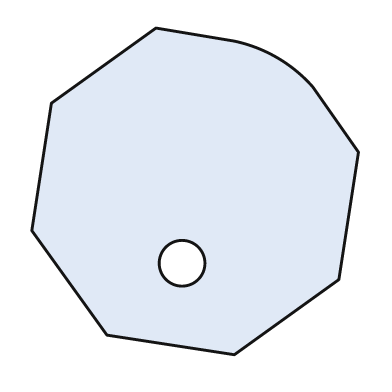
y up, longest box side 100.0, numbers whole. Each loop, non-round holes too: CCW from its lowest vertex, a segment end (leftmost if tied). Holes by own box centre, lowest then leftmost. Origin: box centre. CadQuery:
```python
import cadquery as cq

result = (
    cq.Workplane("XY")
    .moveTo(12.0, -50.0)
    .lineTo(44.0, -27.0)
    .lineTo(50.0, 12.0)
    .lineTo(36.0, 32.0)
    .threePointArc((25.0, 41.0), (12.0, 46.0))
    .lineTo(-12.0, 50.0)
    .lineTo(-44.0, 27.0)
    .lineTo(-50.0, -12.0)
    .lineTo(-27.0, -44.0)
    .close()
    .moveTo(-4.0, -22.0)
    .circle(7.0)
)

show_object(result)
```